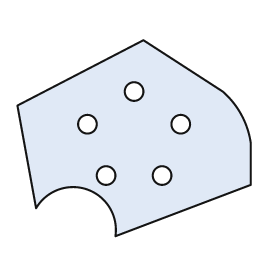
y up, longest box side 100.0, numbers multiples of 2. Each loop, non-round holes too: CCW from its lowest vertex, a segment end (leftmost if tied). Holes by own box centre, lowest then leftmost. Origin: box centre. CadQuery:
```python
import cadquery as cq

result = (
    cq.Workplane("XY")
    .moveTo(-8.0, -42.0)
    .lineTo(50.0, -20.0)
    .lineTo(50.0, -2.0)
    .threePointArc((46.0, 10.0), (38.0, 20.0))
    .lineTo(4.0, 42.0)
    .lineTo(-50.0, 14.0)
    .lineTo(-42.0, -30.0)
    .threePointArc((-20.0, -22.0), (-8.0, -42.0))
    .close()
    .moveTo(-12.0, -16.0)
    .circle(4.0)
    .moveTo(12.0, -16.0)
    .circle(4.0)
    .moveTo(-20.0, 6.0)
    .circle(4.0)
    .moveTo(20.0, 6.0)
    .circle(4.0)
    .moveTo(0.0, 20.0)
    .circle(4.0)
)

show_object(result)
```